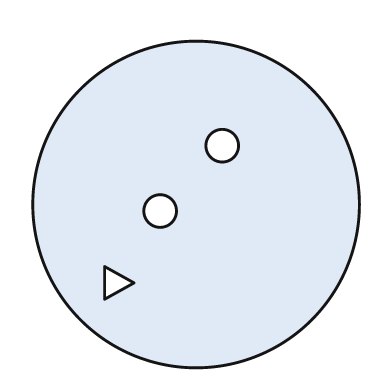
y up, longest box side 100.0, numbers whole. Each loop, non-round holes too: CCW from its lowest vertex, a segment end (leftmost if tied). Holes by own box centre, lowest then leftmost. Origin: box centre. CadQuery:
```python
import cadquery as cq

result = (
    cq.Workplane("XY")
    .moveTo(0.0, 0.0)
    .circle(50.0)
    .moveTo(-28.0, -29.0)
    .lineTo(-19.0, -24.0)
    .lineTo(-28.0, -19.0)
    .close()
    .moveTo(-11.0, -2.0)
    .circle(5.0)
    .moveTo(8.0, 18.0)
    .circle(5.0)
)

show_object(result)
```